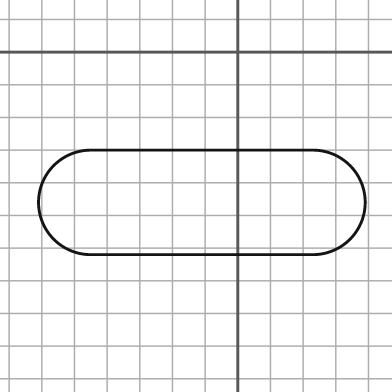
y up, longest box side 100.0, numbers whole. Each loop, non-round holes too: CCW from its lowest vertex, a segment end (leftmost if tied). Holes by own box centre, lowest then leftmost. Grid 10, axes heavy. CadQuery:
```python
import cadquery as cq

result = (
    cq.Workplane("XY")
    .moveTo(-45.0, -62.0)
    .lineTo(23.0, -62.0)
    .threePointArc((39.0, -46.0), (23.0, -30.0))
    .lineTo(-45.0, -30.0)
    .threePointArc((-61.0, -46.0), (-45.0, -62.0))
    .close()
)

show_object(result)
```